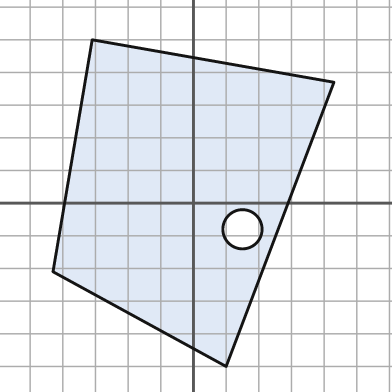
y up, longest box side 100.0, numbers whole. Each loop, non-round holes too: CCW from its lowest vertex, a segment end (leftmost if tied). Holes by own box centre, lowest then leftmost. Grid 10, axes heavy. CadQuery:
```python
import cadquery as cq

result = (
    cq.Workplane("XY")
    .moveTo(10.0, -50.0)
    .lineTo(43.0, 37.0)
    .lineTo(-31.0, 50.0)
    .lineTo(-43.0, -21.0)
    .close()
    .moveTo(15.0, -8.0)
    .circle(6.0)
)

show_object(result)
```